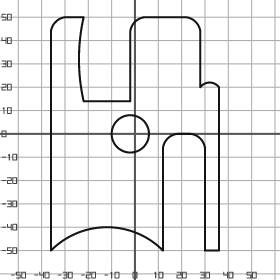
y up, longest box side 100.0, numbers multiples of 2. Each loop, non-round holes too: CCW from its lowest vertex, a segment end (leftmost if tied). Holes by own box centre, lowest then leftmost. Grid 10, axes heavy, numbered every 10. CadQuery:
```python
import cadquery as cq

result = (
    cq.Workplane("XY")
    .moveTo(-36.0, -50.0)
    .threePointArc((-12.0, -40.0), (12.0, -50.0))
    .lineTo(12.0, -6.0)
    .threePointArc((14.0, -2.0), (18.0, 0.0))
    .lineTo(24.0, 0.0)
    .threePointArc((28.0, -2.0), (30.0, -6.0))
    .lineTo(30.0, -50.0)
    .lineTo(36.0, -50.0)
    .lineTo(36.0, 20.0)
    .threePointArc((32.0, 22.0), (28.0, 20.0))
    .lineTo(28.0, 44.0)
    .threePointArc((26.0, 48.0), (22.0, 50.0))
    .lineTo(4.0, 50.0)
    .threePointArc((0.0, 48.0), (-2.0, 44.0))
    .lineTo(-2.0, 14.0)
    .lineTo(-22.0, 14.0)
    .threePointArc((-24.0, 32.0), (-22.0, 50.0))
    .lineTo(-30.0, 50.0)
    .threePointArc((-34.0, 48.0), (-36.0, 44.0))
    .close()
    .moveTo(-2.0, 0.0)
    .circle(8.0)
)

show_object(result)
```